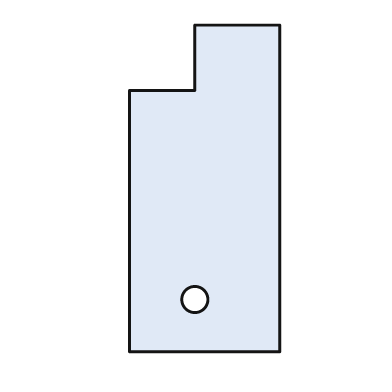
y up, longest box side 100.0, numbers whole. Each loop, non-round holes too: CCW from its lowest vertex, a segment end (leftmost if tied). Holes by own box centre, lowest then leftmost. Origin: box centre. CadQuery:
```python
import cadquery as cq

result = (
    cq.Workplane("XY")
    .moveTo(-23.0, -50.0)
    .lineTo(23.0, -50.0)
    .lineTo(23.0, 50.0)
    .lineTo(-3.0, 50.0)
    .lineTo(-3.0, 30.0)
    .lineTo(-23.0, 30.0)
    .close()
    .moveTo(-3.0, -34.0)
    .circle(4.0)
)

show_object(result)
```